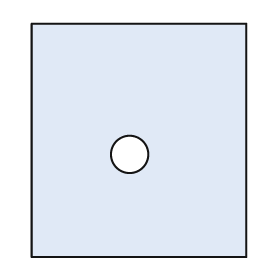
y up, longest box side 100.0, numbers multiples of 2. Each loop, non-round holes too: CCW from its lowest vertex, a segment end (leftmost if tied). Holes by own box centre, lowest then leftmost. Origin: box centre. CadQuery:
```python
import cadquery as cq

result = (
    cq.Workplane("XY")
    .moveTo(-46.0, -50.0)
    .lineTo(46.0, -50.0)
    .lineTo(46.0, 50.0)
    .lineTo(-46.0, 50.0)
    .close()
    .moveTo(-4.0, -6.0)
    .circle(8.0)
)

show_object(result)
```